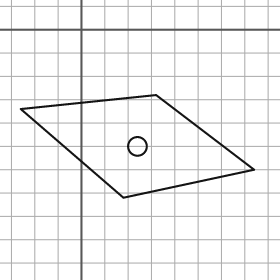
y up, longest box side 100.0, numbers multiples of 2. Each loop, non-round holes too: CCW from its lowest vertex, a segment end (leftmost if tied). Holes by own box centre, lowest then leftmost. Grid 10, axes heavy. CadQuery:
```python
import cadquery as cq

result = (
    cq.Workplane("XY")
    .moveTo(18.0, -72.0)
    .lineTo(74.0, -60.0)
    .lineTo(32.0, -28.0)
    .lineTo(-26.0, -34.0)
    .close()
    .moveTo(24.0, -50.0)
    .circle(4.0)
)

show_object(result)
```